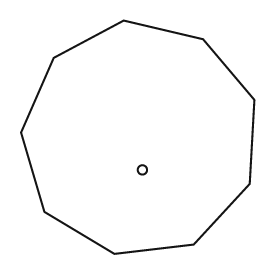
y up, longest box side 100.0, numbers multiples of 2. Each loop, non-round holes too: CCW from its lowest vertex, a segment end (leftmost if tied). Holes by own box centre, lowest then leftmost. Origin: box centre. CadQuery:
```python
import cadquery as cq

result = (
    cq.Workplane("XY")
    .moveTo(-10.0, -50.0)
    .lineTo(24.0, -46.0)
    .lineTo(48.0, -20.0)
    .lineTo(50.0, 16.0)
    .lineTo(28.0, 42.0)
    .lineTo(-6.0, 50.0)
    .lineTo(-36.0, 34.0)
    .lineTo(-50.0, 2.0)
    .lineTo(-40.0, -32.0)
    .close()
    .moveTo(2.0, -14.0)
    .circle(2.0)
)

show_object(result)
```